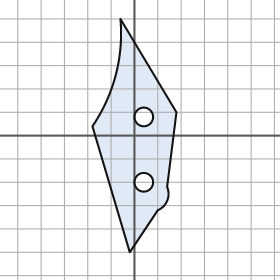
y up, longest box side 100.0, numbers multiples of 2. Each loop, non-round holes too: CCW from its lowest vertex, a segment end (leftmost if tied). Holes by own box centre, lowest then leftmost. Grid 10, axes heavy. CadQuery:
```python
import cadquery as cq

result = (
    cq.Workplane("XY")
    .moveTo(-2.0, -50.0)
    .lineTo(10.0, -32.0)
    .threePointArc((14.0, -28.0), (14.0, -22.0))
    .lineTo(18.0, 10.0)
    .lineTo(-6.0, 50.0)
    .threePointArc((-8.0, 26.0), (-18.0, 4.0))
    .close()
    .moveTo(4.0, -20.0)
    .circle(4.0)
    .moveTo(4.0, 8.0)
    .circle(4.0)
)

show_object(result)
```